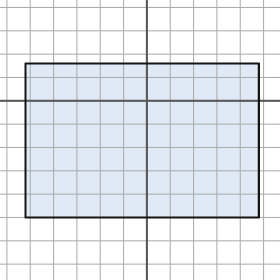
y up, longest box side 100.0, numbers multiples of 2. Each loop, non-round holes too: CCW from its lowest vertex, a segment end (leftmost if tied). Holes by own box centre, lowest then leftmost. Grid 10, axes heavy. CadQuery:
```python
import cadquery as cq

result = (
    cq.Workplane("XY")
    .moveTo(-52.0, -50.0)
    .lineTo(48.0, -50.0)
    .lineTo(48.0, 16.0)
    .lineTo(-52.0, 16.0)
    .close()
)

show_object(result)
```